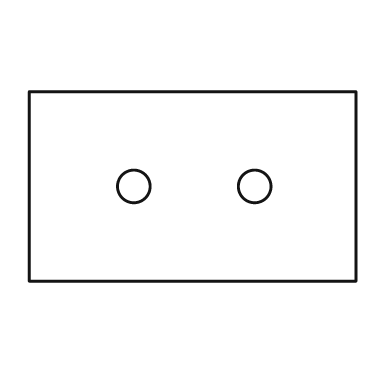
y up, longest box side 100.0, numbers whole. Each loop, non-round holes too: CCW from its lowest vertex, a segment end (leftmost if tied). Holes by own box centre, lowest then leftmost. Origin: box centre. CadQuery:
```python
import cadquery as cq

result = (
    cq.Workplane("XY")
    .moveTo(-50.0, -29.0)
    .lineTo(50.0, -29.0)
    .lineTo(50.0, 29.0)
    .lineTo(-50.0, 29.0)
    .close()
    .moveTo(-18.0, 0.0)
    .circle(5.0)
    .moveTo(19.0, 0.0)
    .circle(5.0)
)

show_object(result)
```